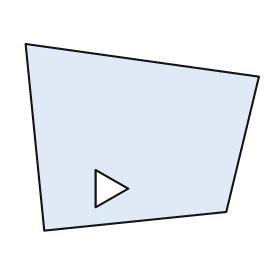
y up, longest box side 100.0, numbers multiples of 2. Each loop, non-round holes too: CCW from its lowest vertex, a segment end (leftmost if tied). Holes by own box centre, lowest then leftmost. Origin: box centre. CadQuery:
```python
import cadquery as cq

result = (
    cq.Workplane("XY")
    .moveTo(-42.0, -40.0)
    .lineTo(36.0, -32.0)
    .lineTo(50.0, 26.0)
    .lineTo(-50.0, 40.0)
    .close()
    .moveTo(-20.0, -30.0)
    .lineTo(-6.0, -22.0)
    .lineTo(-20.0, -14.0)
    .close()
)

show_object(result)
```